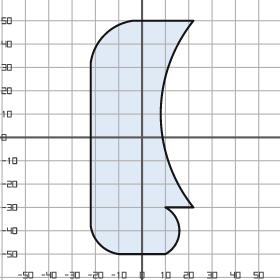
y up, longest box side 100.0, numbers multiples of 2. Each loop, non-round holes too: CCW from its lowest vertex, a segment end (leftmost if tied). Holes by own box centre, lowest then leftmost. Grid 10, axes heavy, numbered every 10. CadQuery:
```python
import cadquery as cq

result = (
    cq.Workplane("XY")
    .moveTo(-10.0, -50.0)
    .lineTo(10.0, -50.0)
    .threePointArc((16.0, -40.0), (10.0, -30.0))
    .lineTo(22.0, -30.0)
    .threePointArc((8.0, 10.0), (22.0, 50.0))
    .lineTo(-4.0, 50.0)
    .threePointArc((-16.0, 44.0), (-22.0, 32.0))
    .lineTo(-22.0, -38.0)
    .threePointArc((-18.0, -46.0), (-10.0, -50.0))
    .close()
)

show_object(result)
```